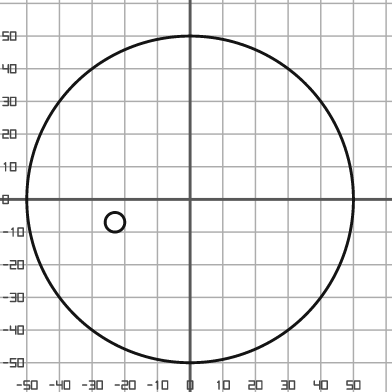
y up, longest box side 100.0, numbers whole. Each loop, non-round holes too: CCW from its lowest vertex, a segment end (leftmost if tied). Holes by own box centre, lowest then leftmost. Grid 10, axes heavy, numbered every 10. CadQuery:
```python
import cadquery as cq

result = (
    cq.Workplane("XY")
    .moveTo(0.0, 0.0)
    .circle(50.0)
    .moveTo(-23.0, -7.0)
    .circle(3.0)
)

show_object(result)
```